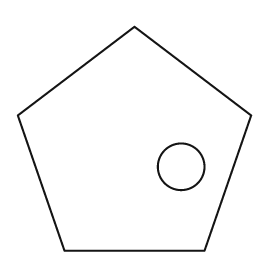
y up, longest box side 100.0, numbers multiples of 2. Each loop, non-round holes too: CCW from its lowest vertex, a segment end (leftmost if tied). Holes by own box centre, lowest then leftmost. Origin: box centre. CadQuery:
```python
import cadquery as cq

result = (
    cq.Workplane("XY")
    .moveTo(-30.0, -48.0)
    .lineTo(30.0, -48.0)
    .lineTo(50.0, 10.0)
    .lineTo(0.0, 48.0)
    .lineTo(-50.0, 10.0)
    .close()
    .moveTo(20.0, -12.0)
    .circle(10.0)
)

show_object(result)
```